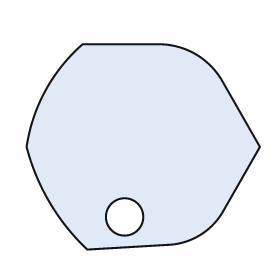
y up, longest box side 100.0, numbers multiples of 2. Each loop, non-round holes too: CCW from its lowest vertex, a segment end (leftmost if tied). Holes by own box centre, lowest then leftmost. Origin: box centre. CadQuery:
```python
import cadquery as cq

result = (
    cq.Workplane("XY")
    .moveTo(-24.0, -44.0)
    .lineTo(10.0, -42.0)
    .threePointArc((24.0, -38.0), (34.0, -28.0))
    .lineTo(50.0, 0.0)
    .lineTo(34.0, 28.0)
    .threePointArc((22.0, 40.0), (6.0, 44.0))
    .lineTo(-26.0, 44.0)
    .threePointArc((-42.0, 24.0), (-50.0, 0.0))
    .threePointArc((-40.0, -24.0), (-24.0, -44.0))
    .close()
    .moveTo(-8.0, -30.0)
    .circle(8.0)
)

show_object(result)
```